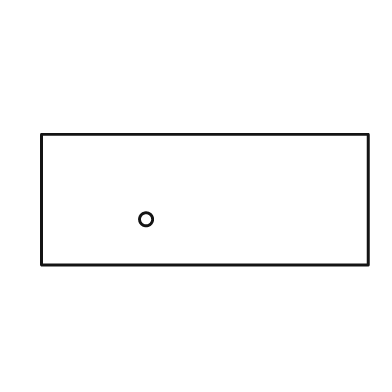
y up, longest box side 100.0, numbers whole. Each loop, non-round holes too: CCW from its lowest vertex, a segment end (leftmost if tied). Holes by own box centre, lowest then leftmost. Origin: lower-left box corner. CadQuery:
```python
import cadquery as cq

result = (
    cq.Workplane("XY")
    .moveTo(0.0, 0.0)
    .lineTo(100.0, 0.0)
    .lineTo(100.0, 40.0)
    .lineTo(0.0, 40.0)
    .close()
    .moveTo(32.0, 14.0)
    .circle(2.0)
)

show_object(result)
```